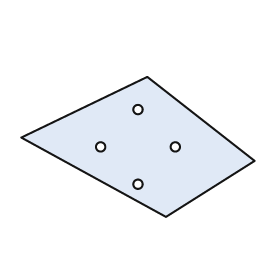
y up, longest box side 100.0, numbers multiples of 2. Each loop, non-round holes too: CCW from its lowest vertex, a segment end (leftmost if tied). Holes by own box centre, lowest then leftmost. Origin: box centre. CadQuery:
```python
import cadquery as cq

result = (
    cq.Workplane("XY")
    .moveTo(12.0, -30.0)
    .lineTo(50.0, -6.0)
    .lineTo(4.0, 30.0)
    .lineTo(-50.0, 4.0)
    .close()
    .moveTo(0.0, -16.0)
    .circle(2.0)
    .moveTo(-16.0, 0.0)
    .circle(2.0)
    .moveTo(16.0, 0.0)
    .circle(2.0)
    .moveTo(0.0, 16.0)
    .circle(2.0)
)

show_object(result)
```